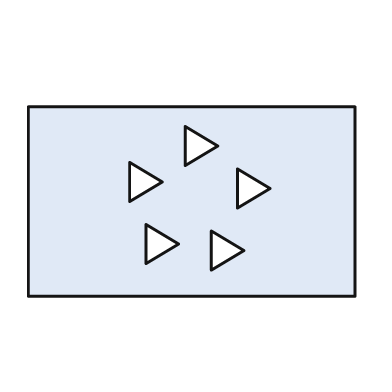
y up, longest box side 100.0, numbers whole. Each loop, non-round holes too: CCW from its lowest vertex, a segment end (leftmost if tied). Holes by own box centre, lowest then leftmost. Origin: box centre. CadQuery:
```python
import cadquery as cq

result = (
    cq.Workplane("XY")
    .moveTo(-50.0, -29.0)
    .lineTo(50.0, -29.0)
    .lineTo(50.0, 29.0)
    .lineTo(-50.0, 29.0)
    .close()
    .moveTo(6.0, -21.0)
    .lineTo(16.0, -15.0)
    .lineTo(6.0, -9.0)
    .close()
    .moveTo(-14.0, -19.0)
    .lineTo(-4.0, -13.0)
    .lineTo(-14.0, -7.0)
    .close()
    .moveTo(14.0, -2.0)
    .lineTo(24.0, 4.0)
    .lineTo(14.0, 10.0)
    .close()
    .moveTo(-19.0, 0.0)
    .lineTo(-9.0, 6.0)
    .lineTo(-19.0, 12.0)
    .close()
    .moveTo(-2.0, 11.0)
    .lineTo(8.0, 17.0)
    .lineTo(-2.0, 23.0)
    .close()
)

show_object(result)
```